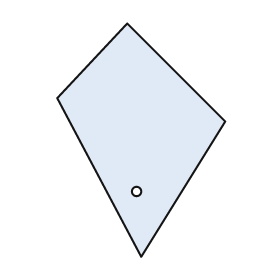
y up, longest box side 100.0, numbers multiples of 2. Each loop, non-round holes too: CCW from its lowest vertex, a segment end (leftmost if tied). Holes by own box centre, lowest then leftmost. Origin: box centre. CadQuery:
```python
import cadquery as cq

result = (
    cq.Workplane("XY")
    .moveTo(0.0, -50.0)
    .lineTo(36.0, 8.0)
    .lineTo(-6.0, 50.0)
    .lineTo(-36.0, 18.0)
    .close()
    .moveTo(-2.0, -22.0)
    .circle(2.0)
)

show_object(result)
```